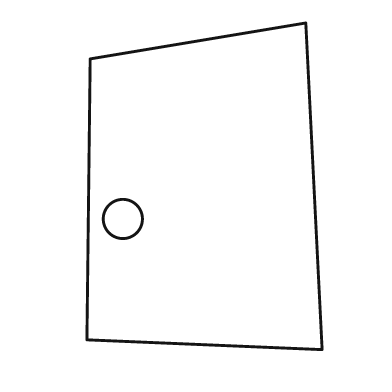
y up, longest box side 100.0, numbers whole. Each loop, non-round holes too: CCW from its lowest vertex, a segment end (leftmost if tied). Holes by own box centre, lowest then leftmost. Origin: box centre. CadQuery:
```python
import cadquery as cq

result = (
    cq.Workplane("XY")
    .moveTo(36.0, -50.0)
    .lineTo(31.0, 50.0)
    .lineTo(-35.0, 39.0)
    .lineTo(-36.0, -47.0)
    .close()
    .moveTo(-25.0, -10.0)
    .circle(6.0)
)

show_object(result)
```